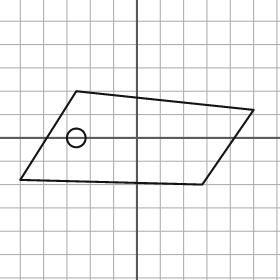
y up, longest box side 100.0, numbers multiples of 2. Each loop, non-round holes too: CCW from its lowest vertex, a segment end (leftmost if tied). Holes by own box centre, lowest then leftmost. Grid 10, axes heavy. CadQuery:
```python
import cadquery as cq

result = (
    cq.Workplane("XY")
    .moveTo(28.0, -20.0)
    .lineTo(50.0, 12.0)
    .lineTo(-26.0, 20.0)
    .lineTo(-50.0, -18.0)
    .close()
    .moveTo(-26.0, 0.0)
    .circle(4.0)
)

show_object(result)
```